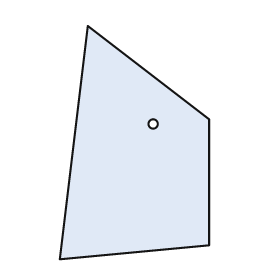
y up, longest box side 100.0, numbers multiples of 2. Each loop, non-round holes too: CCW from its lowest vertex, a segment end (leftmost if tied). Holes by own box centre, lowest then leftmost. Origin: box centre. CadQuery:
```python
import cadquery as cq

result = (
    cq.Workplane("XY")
    .moveTo(-32.0, -50.0)
    .lineTo(32.0, -44.0)
    .lineTo(32.0, 10.0)
    .lineTo(-20.0, 50.0)
    .close()
    .moveTo(8.0, 8.0)
    .circle(2.0)
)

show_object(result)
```